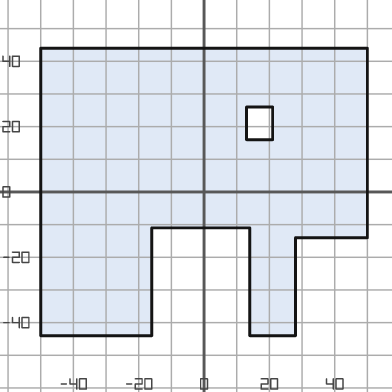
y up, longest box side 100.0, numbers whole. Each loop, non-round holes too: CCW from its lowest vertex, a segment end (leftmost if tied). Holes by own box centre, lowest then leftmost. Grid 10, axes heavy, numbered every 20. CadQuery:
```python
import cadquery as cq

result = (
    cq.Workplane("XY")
    .moveTo(-50.0, -44.0)
    .lineTo(-16.0, -44.0)
    .lineTo(-16.0, -11.0)
    .lineTo(14.0, -11.0)
    .lineTo(14.0, -44.0)
    .lineTo(28.0, -44.0)
    .lineTo(28.0, -14.0)
    .lineTo(50.0, -14.0)
    .lineTo(50.0, 44.0)
    .lineTo(-50.0, 44.0)
    .close()
    .moveTo(13.0, 16.0)
    .lineTo(21.0, 16.0)
    .lineTo(21.0, 26.0)
    .lineTo(13.0, 26.0)
    .close()
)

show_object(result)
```